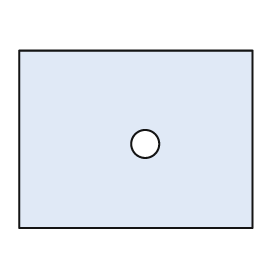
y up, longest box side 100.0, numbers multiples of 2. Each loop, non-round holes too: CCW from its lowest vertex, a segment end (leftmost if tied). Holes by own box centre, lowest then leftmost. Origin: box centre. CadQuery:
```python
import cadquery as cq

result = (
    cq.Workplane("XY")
    .moveTo(-50.0, -38.0)
    .lineTo(50.0, -38.0)
    .lineTo(50.0, 38.0)
    .lineTo(-50.0, 38.0)
    .close()
    .moveTo(4.0, -2.0)
    .circle(6.0)
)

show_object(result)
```